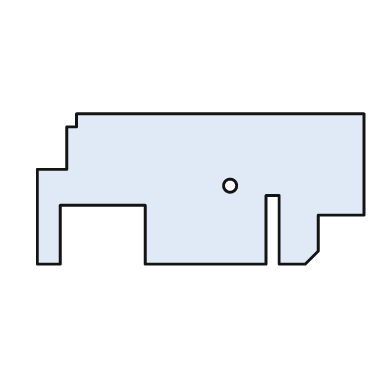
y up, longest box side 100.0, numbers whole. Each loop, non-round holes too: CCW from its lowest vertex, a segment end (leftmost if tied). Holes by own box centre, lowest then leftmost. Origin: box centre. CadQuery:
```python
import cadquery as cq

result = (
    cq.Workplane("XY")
    .moveTo(-50.0, -23.0)
    .lineTo(-43.0, -23.0)
    .lineTo(-43.0, -5.0)
    .lineTo(-17.0, -5.0)
    .lineTo(-17.0, -23.0)
    .lineTo(20.0, -23.0)
    .lineTo(20.0, -2.0)
    .lineTo(24.0, -2.0)
    .lineTo(24.0, -23.0)
    .lineTo(32.0, -23.0)
    .lineTo(36.0, -19.0)
    .lineTo(36.0, -8.0)
    .lineTo(50.0, -8.0)
    .lineTo(50.0, 23.0)
    .lineTo(-38.0, 23.0)
    .lineTo(-38.0, 19.0)
    .lineTo(-41.0, 19.0)
    .lineTo(-41.0, 6.0)
    .lineTo(-50.0, 6.0)
    .close()
    .moveTo(9.0, 1.0)
    .circle(2.0)
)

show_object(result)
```